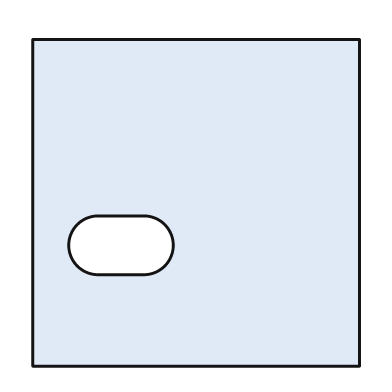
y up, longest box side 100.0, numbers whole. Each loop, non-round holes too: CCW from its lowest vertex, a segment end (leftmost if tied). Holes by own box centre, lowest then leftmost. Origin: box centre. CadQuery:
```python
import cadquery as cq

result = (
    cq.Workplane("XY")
    .moveTo(-50.0, -50.0)
    .lineTo(50.0, -50.0)
    .lineTo(50.0, 50.0)
    .lineTo(-50.0, 50.0)
    .close()
    .moveTo(-30.0, -22.0)
    .lineTo(-16.0, -22.0)
    .threePointArc((-7.0, -13.0), (-16.0, -4.0))
    .lineTo(-30.0, -4.0)
    .threePointArc((-39.0, -13.0), (-30.0, -22.0))
    .close()
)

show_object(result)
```